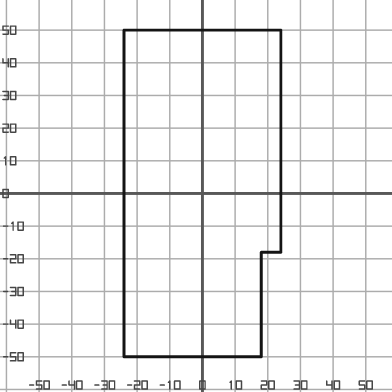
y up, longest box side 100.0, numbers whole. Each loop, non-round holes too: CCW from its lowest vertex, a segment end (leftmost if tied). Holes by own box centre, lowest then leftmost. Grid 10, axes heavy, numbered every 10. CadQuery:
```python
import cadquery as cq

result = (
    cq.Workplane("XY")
    .moveTo(-24.0, -50.0)
    .lineTo(18.0, -50.0)
    .lineTo(18.0, -18.0)
    .lineTo(24.0, -18.0)
    .lineTo(24.0, 50.0)
    .lineTo(-24.0, 50.0)
    .close()
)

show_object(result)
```